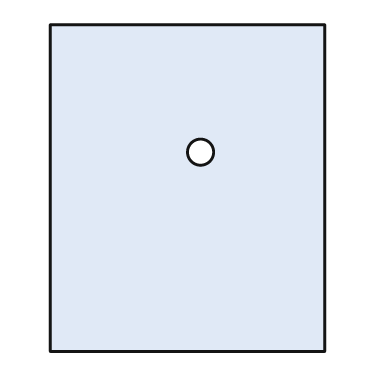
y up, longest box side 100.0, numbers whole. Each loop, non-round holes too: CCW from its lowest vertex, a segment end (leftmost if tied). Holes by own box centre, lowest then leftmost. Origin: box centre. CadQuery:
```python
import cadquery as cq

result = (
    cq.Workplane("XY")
    .moveTo(-42.0, -50.0)
    .lineTo(42.0, -50.0)
    .lineTo(42.0, 50.0)
    .lineTo(-42.0, 50.0)
    .close()
    .moveTo(4.0, 11.0)
    .circle(4.0)
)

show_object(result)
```